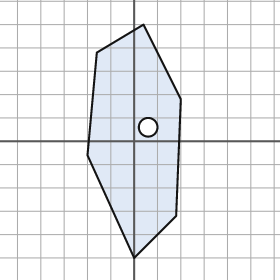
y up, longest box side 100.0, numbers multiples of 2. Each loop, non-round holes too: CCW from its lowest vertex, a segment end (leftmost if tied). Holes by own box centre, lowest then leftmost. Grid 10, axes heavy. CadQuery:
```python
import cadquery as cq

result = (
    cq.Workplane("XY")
    .moveTo(0.0, -50.0)
    .lineTo(18.0, -32.0)
    .lineTo(20.0, 18.0)
    .lineTo(4.0, 50.0)
    .lineTo(-16.0, 38.0)
    .lineTo(-20.0, -6.0)
    .close()
    .moveTo(6.0, 6.0)
    .circle(4.0)
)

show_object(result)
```